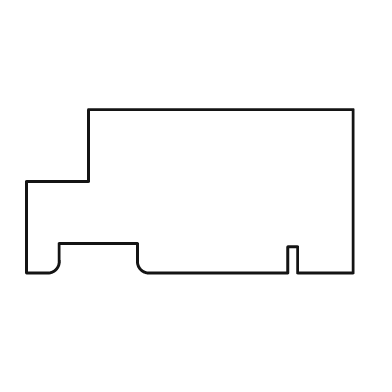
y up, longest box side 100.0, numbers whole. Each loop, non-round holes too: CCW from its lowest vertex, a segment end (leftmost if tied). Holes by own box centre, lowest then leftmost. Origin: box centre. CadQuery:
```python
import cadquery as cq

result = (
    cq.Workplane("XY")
    .moveTo(-50.0, -25.0)
    .lineTo(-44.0, -25.0)
    .threePointArc((-41.0, -24.0), (-40.0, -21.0))
    .lineTo(-40.0, -16.0)
    .lineTo(-16.0, -16.0)
    .lineTo(-16.0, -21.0)
    .threePointArc((-15.0, -24.0), (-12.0, -25.0))
    .lineTo(30.0, -25.0)
    .lineTo(30.0, -17.0)
    .lineTo(33.0, -17.0)
    .lineTo(33.0, -25.0)
    .lineTo(50.0, -25.0)
    .lineTo(50.0, 25.0)
    .lineTo(-31.0, 25.0)
    .lineTo(-31.0, 3.0)
    .lineTo(-50.0, 3.0)
    .close()
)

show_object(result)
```